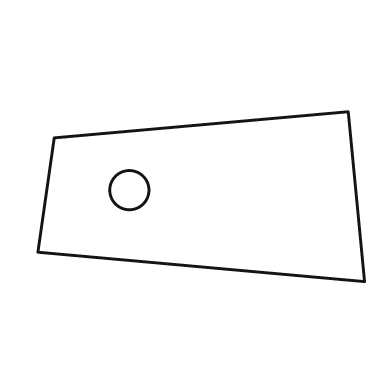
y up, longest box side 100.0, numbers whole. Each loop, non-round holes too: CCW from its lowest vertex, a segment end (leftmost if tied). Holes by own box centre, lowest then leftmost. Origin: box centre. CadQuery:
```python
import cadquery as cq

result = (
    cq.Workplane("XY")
    .moveTo(50.0, -26.0)
    .lineTo(45.0, 26.0)
    .lineTo(-45.0, 18.0)
    .lineTo(-50.0, -17.0)
    .close()
    .moveTo(-22.0, 2.0)
    .circle(6.0)
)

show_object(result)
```